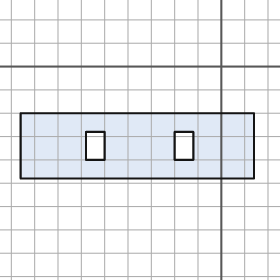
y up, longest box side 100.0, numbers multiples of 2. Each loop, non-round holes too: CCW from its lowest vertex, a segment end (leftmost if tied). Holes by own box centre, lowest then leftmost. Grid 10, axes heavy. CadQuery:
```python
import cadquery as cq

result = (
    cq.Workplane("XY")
    .moveTo(-86.0, -48.0)
    .lineTo(14.0, -48.0)
    .lineTo(14.0, -20.0)
    .lineTo(-86.0, -20.0)
    .close()
    .moveTo(-58.0, -40.0)
    .lineTo(-50.0, -40.0)
    .lineTo(-50.0, -28.0)
    .lineTo(-58.0, -28.0)
    .close()
    .moveTo(-20.0, -40.0)
    .lineTo(-12.0, -40.0)
    .lineTo(-12.0, -28.0)
    .lineTo(-20.0, -28.0)
    .close()
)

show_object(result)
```